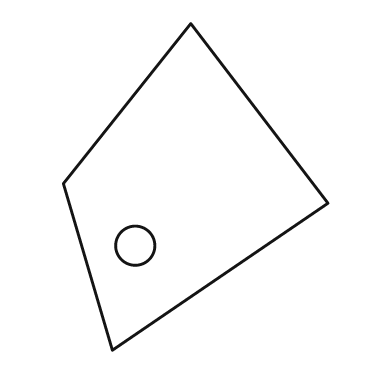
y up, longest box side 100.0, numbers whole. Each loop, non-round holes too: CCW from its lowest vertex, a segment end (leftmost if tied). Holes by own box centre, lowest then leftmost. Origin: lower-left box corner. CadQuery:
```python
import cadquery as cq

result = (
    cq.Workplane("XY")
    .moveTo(15.0, 0.0)
    .lineTo(81.0, 45.0)
    .lineTo(39.0, 100.0)
    .lineTo(0.0, 51.0)
    .close()
    .moveTo(22.0, 32.0)
    .circle(6.0)
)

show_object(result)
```